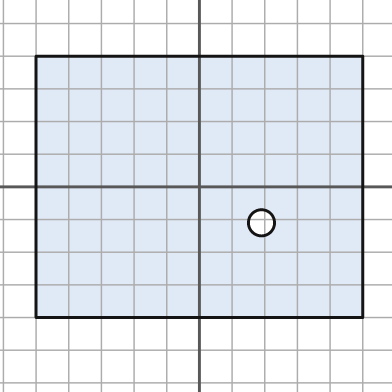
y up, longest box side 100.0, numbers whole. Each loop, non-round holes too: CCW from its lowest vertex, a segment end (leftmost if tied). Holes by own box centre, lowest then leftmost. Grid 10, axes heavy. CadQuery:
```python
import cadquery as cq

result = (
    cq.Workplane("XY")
    .moveTo(-50.0, -40.0)
    .lineTo(50.0, -40.0)
    .lineTo(50.0, 40.0)
    .lineTo(-50.0, 40.0)
    .close()
    .moveTo(19.0, -11.0)
    .circle(4.0)
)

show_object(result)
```